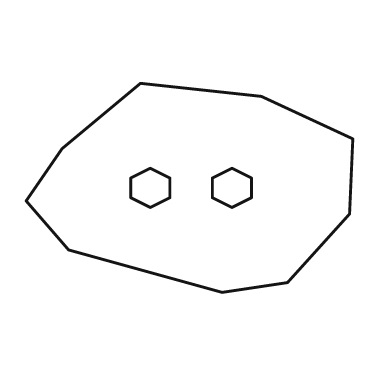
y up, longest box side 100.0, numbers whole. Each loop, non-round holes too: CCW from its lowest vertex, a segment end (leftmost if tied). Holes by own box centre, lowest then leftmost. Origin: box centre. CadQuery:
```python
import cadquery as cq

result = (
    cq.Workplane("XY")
    .moveTo(10.0, -32.0)
    .lineTo(30.0, -29.0)
    .lineTo(49.0, -8.0)
    .lineTo(50.0, 15.0)
    .lineTo(22.0, 28.0)
    .lineTo(-15.0, 32.0)
    .lineTo(-39.0, 12.0)
    .lineTo(-50.0, -4.0)
    .lineTo(-37.0, -19.0)
    .close()
    .moveTo(-12.0, -6.0)
    .lineTo(-6.0, -3.0)
    .lineTo(-6.0, 3.0)
    .lineTo(-12.0, 6.0)
    .lineTo(-18.0, 3.0)
    .lineTo(-18.0, -3.0)
    .close()
    .moveTo(13.0, -6.0)
    .lineTo(19.0, -3.0)
    .lineTo(19.0, 3.0)
    .lineTo(13.0, 6.0)
    .lineTo(7.0, 3.0)
    .lineTo(7.0, -3.0)
    .close()
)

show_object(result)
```